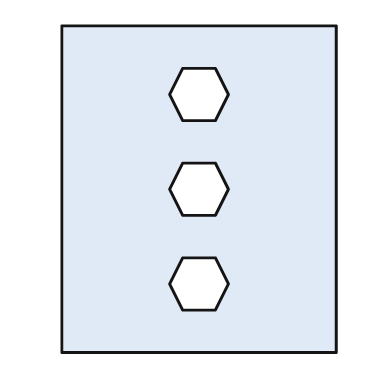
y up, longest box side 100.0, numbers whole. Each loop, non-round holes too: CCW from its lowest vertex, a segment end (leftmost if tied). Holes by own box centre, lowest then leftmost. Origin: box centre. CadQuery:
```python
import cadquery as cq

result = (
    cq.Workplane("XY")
    .moveTo(-42.0, -50.0)
    .lineTo(42.0, -50.0)
    .lineTo(42.0, 50.0)
    .lineTo(-42.0, 50.0)
    .close()
    .moveTo(-5.0, -37.0)
    .lineTo(5.0, -37.0)
    .lineTo(9.0, -29.0)
    .lineTo(5.0, -21.0)
    .lineTo(-5.0, -21.0)
    .lineTo(-9.0, -29.0)
    .close()
    .moveTo(-5.0, -8.0)
    .lineTo(5.0, -8.0)
    .lineTo(9.0, 0.0)
    .lineTo(5.0, 8.0)
    .lineTo(-5.0, 8.0)
    .lineTo(-9.0, 0.0)
    .close()
    .moveTo(-5.0, 21.0)
    .lineTo(5.0, 21.0)
    .lineTo(9.0, 29.0)
    .lineTo(5.0, 37.0)
    .lineTo(-5.0, 37.0)
    .lineTo(-9.0, 29.0)
    .close()
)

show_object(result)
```